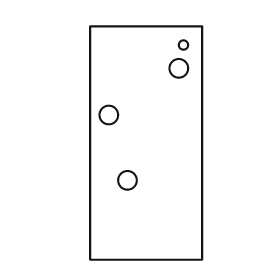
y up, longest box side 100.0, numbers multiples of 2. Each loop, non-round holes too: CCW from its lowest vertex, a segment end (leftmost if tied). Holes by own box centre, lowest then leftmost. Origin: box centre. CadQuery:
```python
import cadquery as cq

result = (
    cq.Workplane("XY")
    .moveTo(-24.0, -50.0)
    .lineTo(24.0, -50.0)
    .lineTo(24.0, 50.0)
    .lineTo(-24.0, 50.0)
    .close()
    .moveTo(-8.0, -16.0)
    .circle(4.0)
    .moveTo(-16.0, 12.0)
    .circle(4.0)
    .moveTo(14.0, 32.0)
    .circle(4.0)
    .moveTo(16.0, 42.0)
    .circle(2.0)
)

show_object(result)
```